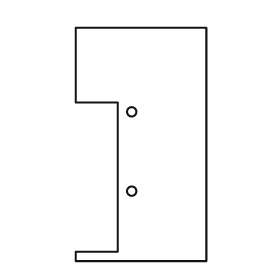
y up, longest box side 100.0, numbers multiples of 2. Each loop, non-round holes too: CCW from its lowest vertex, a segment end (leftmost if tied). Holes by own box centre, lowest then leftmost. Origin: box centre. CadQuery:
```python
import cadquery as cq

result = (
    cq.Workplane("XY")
    .moveTo(-28.0, -50.0)
    .lineTo(28.0, -50.0)
    .lineTo(28.0, 50.0)
    .lineTo(-28.0, 50.0)
    .lineTo(-28.0, 18.0)
    .lineTo(-10.0, 18.0)
    .lineTo(-10.0, -46.0)
    .lineTo(-28.0, -46.0)
    .close()
    .moveTo(-4.0, -20.0)
    .circle(2.0)
    .moveTo(-4.0, 14.0)
    .circle(2.0)
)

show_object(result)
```